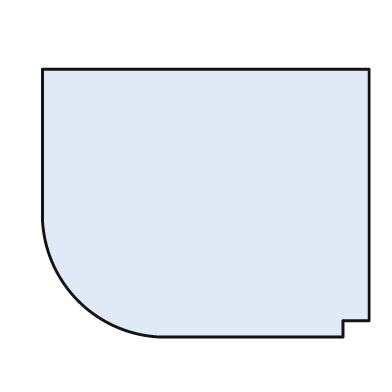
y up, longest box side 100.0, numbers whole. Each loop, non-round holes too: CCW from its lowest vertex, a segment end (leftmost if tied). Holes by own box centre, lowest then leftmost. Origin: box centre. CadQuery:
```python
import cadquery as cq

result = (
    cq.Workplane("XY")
    .moveTo(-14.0, -41.0)
    .lineTo(42.0, -41.0)
    .lineTo(42.0, -36.0)
    .lineTo(50.0, -36.0)
    .lineTo(50.0, 41.0)
    .lineTo(-50.0, 41.0)
    .lineTo(-50.0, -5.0)
    .threePointArc((-39.0, -30.0), (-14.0, -41.0))
    .close()
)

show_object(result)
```